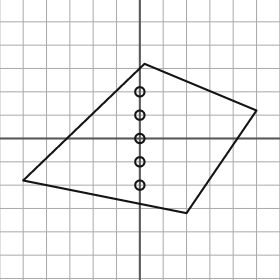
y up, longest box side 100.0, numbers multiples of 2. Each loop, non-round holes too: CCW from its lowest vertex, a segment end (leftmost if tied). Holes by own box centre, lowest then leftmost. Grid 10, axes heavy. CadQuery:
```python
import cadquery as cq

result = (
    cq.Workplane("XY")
    .moveTo(20.0, -32.0)
    .lineTo(50.0, 12.0)
    .lineTo(2.0, 32.0)
    .lineTo(-50.0, -18.0)
    .close()
    .moveTo(0.0, -20.0)
    .circle(2.0)
    .moveTo(0.0, -10.0)
    .circle(2.0)
    .moveTo(0.0, 0.0)
    .circle(2.0)
    .moveTo(0.0, 10.0)
    .circle(2.0)
    .moveTo(0.0, 20.0)
    .circle(2.0)
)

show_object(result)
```